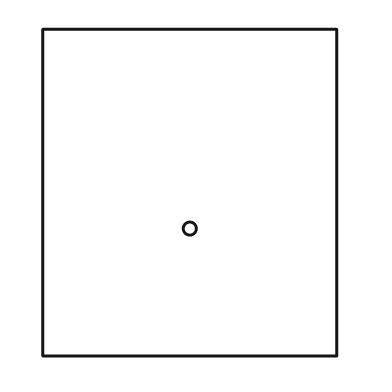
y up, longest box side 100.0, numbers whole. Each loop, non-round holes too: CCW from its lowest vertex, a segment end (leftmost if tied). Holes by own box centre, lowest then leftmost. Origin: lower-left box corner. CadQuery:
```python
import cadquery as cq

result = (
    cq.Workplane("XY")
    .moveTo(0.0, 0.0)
    .lineTo(90.0, 0.0)
    .lineTo(90.0, 100.0)
    .lineTo(0.0, 100.0)
    .close()
    .moveTo(45.0, 39.0)
    .circle(2.0)
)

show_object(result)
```